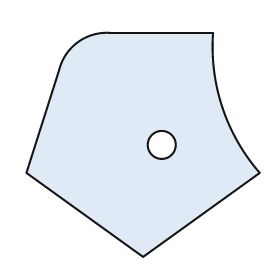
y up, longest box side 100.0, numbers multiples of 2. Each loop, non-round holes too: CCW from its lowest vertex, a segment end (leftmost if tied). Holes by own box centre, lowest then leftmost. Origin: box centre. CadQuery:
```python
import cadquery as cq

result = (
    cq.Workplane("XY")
    .moveTo(0.0, -48.0)
    .lineTo(50.0, -12.0)
    .threePointArc((34.0, 16.0), (30.0, 48.0))
    .lineTo(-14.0, 48.0)
    .threePointArc((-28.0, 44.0), (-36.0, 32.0))
    .lineTo(-50.0, -12.0)
    .close()
    .moveTo(8.0, 0.0)
    .circle(6.0)
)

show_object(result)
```